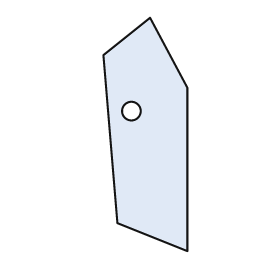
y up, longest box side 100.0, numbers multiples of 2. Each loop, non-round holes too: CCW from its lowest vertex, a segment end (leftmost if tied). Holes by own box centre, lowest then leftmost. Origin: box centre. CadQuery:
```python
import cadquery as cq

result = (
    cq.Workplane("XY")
    .moveTo(18.0, -50.0)
    .lineTo(18.0, 20.0)
    .lineTo(2.0, 50.0)
    .lineTo(-18.0, 34.0)
    .lineTo(-12.0, -38.0)
    .close()
    .moveTo(-6.0, 10.0)
    .circle(4.0)
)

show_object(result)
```